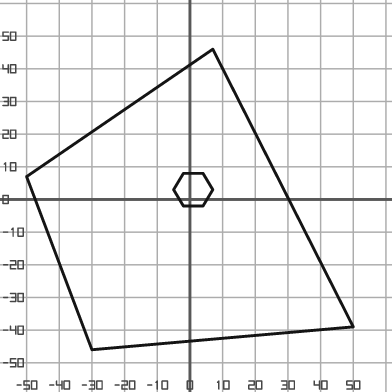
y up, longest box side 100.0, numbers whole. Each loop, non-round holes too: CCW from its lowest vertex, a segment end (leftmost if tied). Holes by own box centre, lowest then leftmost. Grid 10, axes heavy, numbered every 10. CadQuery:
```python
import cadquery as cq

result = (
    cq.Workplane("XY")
    .moveTo(-30.0, -46.0)
    .lineTo(50.0, -39.0)
    .lineTo(7.0, 46.0)
    .lineTo(-50.0, 7.0)
    .close()
    .moveTo(-2.0, -2.0)
    .lineTo(4.0, -2.0)
    .lineTo(7.0, 3.0)
    .lineTo(4.0, 8.0)
    .lineTo(-2.0, 8.0)
    .lineTo(-5.0, 3.0)
    .close()
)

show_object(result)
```